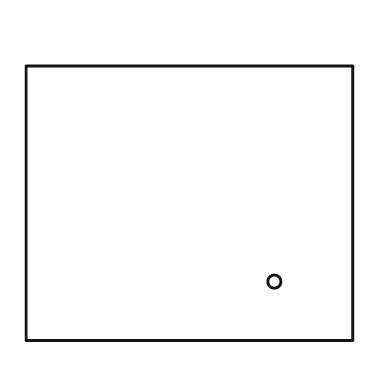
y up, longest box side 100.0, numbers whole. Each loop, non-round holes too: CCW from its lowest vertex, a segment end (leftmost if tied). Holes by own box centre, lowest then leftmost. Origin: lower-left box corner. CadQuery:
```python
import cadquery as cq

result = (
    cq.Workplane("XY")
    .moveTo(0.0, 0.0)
    .lineTo(100.0, 0.0)
    .lineTo(100.0, 84.0)
    .lineTo(0.0, 84.0)
    .close()
    .moveTo(76.0, 18.0)
    .circle(2.0)
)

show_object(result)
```